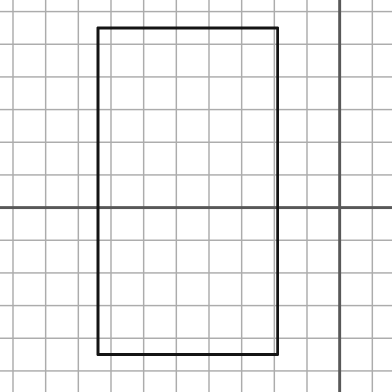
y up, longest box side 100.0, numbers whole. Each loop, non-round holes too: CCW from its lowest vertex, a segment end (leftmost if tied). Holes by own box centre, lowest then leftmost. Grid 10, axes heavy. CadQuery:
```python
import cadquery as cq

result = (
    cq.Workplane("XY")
    .moveTo(-74.0, -45.0)
    .lineTo(-19.0, -45.0)
    .lineTo(-19.0, 55.0)
    .lineTo(-74.0, 55.0)
    .close()
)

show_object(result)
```